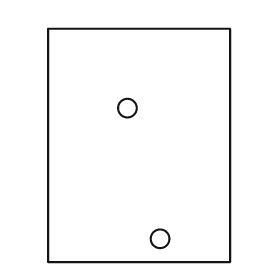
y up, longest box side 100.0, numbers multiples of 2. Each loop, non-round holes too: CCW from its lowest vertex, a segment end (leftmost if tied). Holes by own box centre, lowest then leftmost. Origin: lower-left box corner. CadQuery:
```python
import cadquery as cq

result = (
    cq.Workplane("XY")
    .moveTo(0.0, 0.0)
    .lineTo(78.0, 0.0)
    .lineTo(78.0, 100.0)
    .lineTo(0.0, 100.0)
    .close()
    .moveTo(48.0, 10.0)
    .circle(4.0)
    .moveTo(34.0, 66.0)
    .circle(4.0)
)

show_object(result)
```